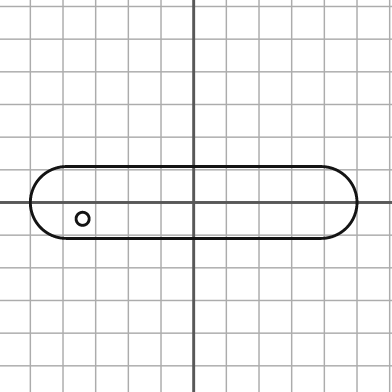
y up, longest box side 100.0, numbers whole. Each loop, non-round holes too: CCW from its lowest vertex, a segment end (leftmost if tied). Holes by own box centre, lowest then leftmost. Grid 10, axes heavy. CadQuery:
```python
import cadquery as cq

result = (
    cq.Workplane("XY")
    .moveTo(-39.0, -11.0)
    .lineTo(39.0, -11.0)
    .threePointArc((50.0, 0.0), (39.0, 11.0))
    .lineTo(-39.0, 11.0)
    .threePointArc((-50.0, 0.0), (-39.0, -11.0))
    .close()
    .moveTo(-34.0, -5.0)
    .circle(2.0)
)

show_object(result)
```